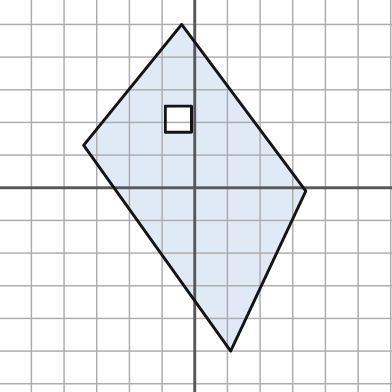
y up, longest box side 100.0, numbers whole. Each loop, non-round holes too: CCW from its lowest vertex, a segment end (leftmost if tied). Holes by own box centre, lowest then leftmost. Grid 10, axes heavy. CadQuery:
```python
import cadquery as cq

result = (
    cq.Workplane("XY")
    .moveTo(11.0, -50.0)
    .lineTo(34.0, -1.0)
    .lineTo(-4.0, 50.0)
    .lineTo(-34.0, 13.0)
    .close()
    .moveTo(-9.0, 17.0)
    .lineTo(-1.0, 17.0)
    .lineTo(-1.0, 25.0)
    .lineTo(-9.0, 25.0)
    .close()
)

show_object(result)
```